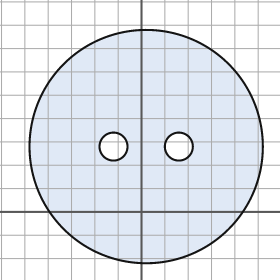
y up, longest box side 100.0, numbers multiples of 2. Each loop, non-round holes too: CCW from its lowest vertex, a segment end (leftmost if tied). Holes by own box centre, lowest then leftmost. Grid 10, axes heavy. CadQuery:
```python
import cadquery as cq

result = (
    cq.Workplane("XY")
    .moveTo(2.0, 28.0)
    .circle(50.0)
    .moveTo(-12.0, 28.0)
    .circle(6.0)
    .moveTo(16.0, 28.0)
    .circle(6.0)
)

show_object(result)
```